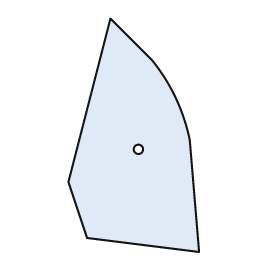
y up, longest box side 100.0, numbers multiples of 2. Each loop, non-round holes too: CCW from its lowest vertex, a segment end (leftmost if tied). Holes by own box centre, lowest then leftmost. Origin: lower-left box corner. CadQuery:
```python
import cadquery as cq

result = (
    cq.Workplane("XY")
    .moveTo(56.0, 0.0)
    .lineTo(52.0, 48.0)
    .threePointArc((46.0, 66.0), (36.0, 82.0))
    .lineTo(18.0, 100.0)
    .lineTo(0.0, 30.0)
    .lineTo(8.0, 6.0)
    .close()
    .moveTo(30.0, 44.0)
    .circle(2.0)
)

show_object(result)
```